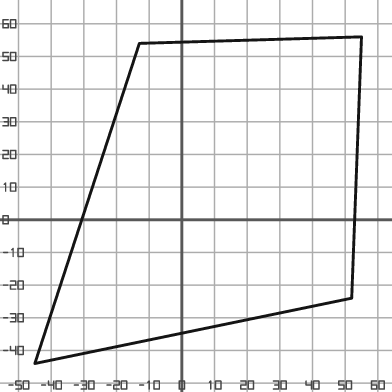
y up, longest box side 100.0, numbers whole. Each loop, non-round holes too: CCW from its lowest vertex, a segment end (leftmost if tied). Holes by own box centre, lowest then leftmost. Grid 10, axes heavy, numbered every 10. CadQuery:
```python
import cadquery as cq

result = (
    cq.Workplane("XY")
    .moveTo(-45.0, -44.0)
    .lineTo(52.0, -24.0)
    .lineTo(55.0, 56.0)
    .lineTo(-13.0, 54.0)
    .close()
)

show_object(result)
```